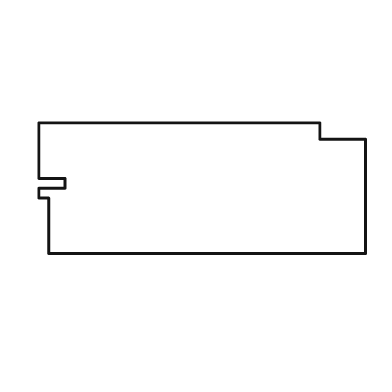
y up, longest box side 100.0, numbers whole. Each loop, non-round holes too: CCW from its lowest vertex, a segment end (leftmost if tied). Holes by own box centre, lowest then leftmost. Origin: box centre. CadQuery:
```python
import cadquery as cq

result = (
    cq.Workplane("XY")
    .moveTo(-47.0, -20.0)
    .lineTo(50.0, -20.0)
    .lineTo(50.0, 15.0)
    .lineTo(36.0, 15.0)
    .lineTo(36.0, 20.0)
    .lineTo(-50.0, 20.0)
    .lineTo(-50.0, 3.0)
    .lineTo(-42.0, 3.0)
    .lineTo(-42.0, 0.0)
    .lineTo(-50.0, 0.0)
    .lineTo(-50.0, -3.0)
    .lineTo(-47.0, -3.0)
    .close()
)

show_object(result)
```